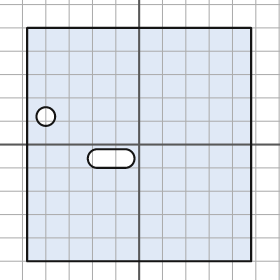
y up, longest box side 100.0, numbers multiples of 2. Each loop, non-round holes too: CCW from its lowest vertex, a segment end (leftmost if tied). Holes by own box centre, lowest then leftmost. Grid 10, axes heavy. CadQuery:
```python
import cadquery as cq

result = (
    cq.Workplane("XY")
    .moveTo(-48.0, -50.0)
    .lineTo(48.0, -50.0)
    .lineTo(48.0, 50.0)
    .lineTo(-48.0, 50.0)
    .close()
    .moveTo(-18.0, -10.0)
    .lineTo(-6.0, -10.0)
    .threePointArc((-2.0, -6.0), (-6.0, -2.0))
    .lineTo(-18.0, -2.0)
    .threePointArc((-22.0, -6.0), (-18.0, -10.0))
    .close()
    .moveTo(-40.0, 12.0)
    .circle(4.0)
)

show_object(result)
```